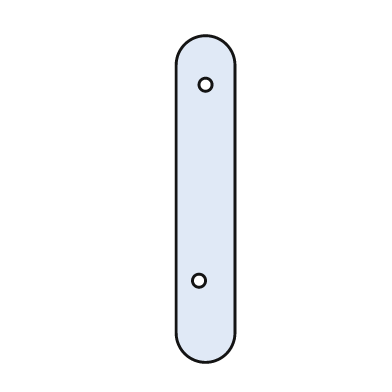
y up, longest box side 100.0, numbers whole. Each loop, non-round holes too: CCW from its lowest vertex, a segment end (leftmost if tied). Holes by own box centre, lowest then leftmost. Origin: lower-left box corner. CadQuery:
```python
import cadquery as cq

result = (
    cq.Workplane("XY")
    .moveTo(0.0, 9.0)
    .threePointArc((9.0, 0.0), (18.0, 9.0))
    .lineTo(18.0, 91.0)
    .threePointArc((9.0, 100.0), (0.0, 91.0))
    .close()
    .moveTo(7.0, 25.0)
    .circle(2.0)
    .moveTo(9.0, 85.0)
    .circle(2.0)
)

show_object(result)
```